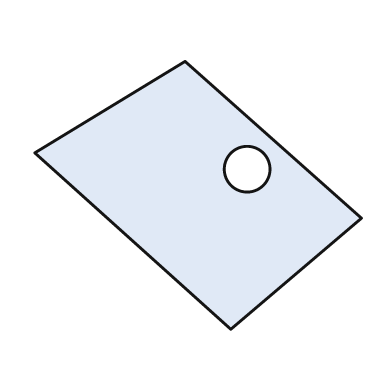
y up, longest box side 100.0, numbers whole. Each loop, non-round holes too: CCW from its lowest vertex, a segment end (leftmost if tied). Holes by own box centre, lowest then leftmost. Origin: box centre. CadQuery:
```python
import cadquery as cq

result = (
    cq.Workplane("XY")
    .moveTo(10.0, -41.0)
    .lineTo(50.0, -7.0)
    .lineTo(-4.0, 41.0)
    .lineTo(-50.0, 13.0)
    .close()
    .moveTo(15.0, 8.0)
    .circle(7.0)
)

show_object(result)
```